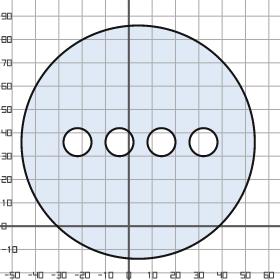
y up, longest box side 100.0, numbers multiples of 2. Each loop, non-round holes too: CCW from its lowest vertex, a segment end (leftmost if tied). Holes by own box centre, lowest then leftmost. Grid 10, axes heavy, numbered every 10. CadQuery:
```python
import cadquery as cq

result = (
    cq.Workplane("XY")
    .moveTo(4.0, 36.0)
    .circle(50.0)
    .moveTo(-22.0, 36.0)
    .circle(6.0)
    .moveTo(-4.0, 36.0)
    .circle(6.0)
    .moveTo(14.0, 36.0)
    .circle(6.0)
    .moveTo(32.0, 36.0)
    .circle(6.0)
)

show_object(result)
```